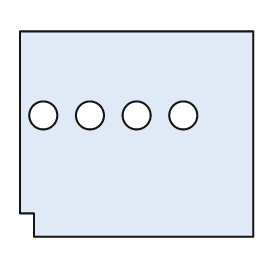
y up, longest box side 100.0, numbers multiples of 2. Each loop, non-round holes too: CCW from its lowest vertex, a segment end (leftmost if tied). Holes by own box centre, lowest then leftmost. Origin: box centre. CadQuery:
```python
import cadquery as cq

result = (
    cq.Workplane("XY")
    .moveTo(-44.0, -44.0)
    .lineTo(50.0, -44.0)
    .lineTo(50.0, 44.0)
    .lineTo(-50.0, 44.0)
    .lineTo(-50.0, -34.0)
    .lineTo(-44.0, -34.0)
    .close()
    .moveTo(-40.0, 8.0)
    .circle(6.0)
    .moveTo(-20.0, 8.0)
    .circle(6.0)
    .moveTo(0.0, 8.0)
    .circle(6.0)
    .moveTo(20.0, 8.0)
    .circle(6.0)
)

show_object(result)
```